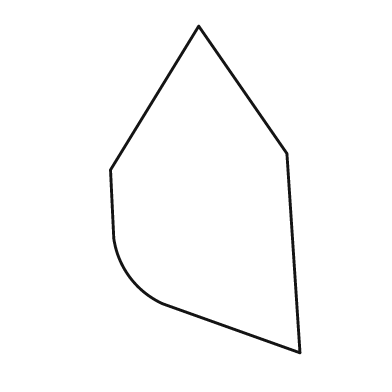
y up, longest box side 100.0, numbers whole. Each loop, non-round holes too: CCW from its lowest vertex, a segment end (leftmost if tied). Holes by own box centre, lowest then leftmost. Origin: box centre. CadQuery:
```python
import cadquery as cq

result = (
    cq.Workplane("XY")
    .moveTo(29.0, -50.0)
    .lineTo(25.0, 11.0)
    .lineTo(-2.0, 50.0)
    .lineTo(-29.0, 6.0)
    .lineTo(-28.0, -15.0)
    .threePointArc((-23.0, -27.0), (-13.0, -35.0))
    .close()
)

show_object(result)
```